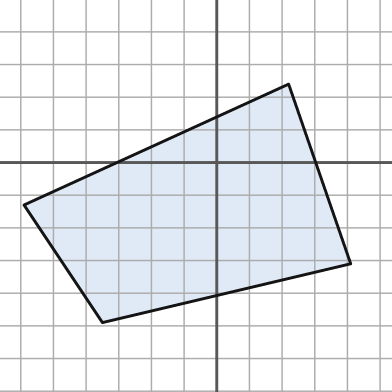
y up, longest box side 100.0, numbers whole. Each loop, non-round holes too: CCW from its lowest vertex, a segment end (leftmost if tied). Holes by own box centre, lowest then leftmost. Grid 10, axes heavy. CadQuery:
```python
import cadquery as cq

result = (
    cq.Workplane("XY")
    .moveTo(-35.0, -49.0)
    .lineTo(41.0, -31.0)
    .lineTo(22.0, 24.0)
    .lineTo(-59.0, -13.0)
    .close()
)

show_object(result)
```